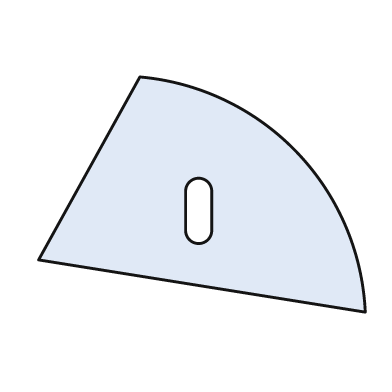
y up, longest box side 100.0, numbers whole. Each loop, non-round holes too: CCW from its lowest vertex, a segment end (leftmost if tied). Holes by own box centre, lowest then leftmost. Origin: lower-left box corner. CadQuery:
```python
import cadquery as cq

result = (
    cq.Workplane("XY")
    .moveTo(100.0, 0.0)
    .threePointArc((79.0, 49.0), (31.0, 72.0))
    .lineTo(0.0, 16.0)
    .close()
    .moveTo(45.0, 25.0)
    .threePointArc((49.0, 21.0), (53.0, 25.0))
    .lineTo(53.0, 37.0)
    .threePointArc((49.0, 41.0), (45.0, 37.0))
    .close()
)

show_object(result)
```